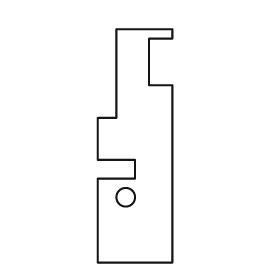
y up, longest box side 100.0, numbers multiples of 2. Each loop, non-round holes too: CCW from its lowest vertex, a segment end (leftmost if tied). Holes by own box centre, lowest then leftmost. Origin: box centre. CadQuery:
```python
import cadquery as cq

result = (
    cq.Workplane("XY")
    .moveTo(-16.0, -50.0)
    .lineTo(16.0, -50.0)
    .lineTo(16.0, 26.0)
    .lineTo(6.0, 26.0)
    .lineTo(6.0, 46.0)
    .lineTo(16.0, 46.0)
    .lineTo(16.0, 50.0)
    .lineTo(-8.0, 50.0)
    .lineTo(-8.0, 12.0)
    .lineTo(-16.0, 12.0)
    .lineTo(-16.0, -6.0)
    .lineTo(0.0, -6.0)
    .lineTo(0.0, -14.0)
    .lineTo(-16.0, -14.0)
    .close()
    .moveTo(-4.0, -22.0)
    .circle(4.0)
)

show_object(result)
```